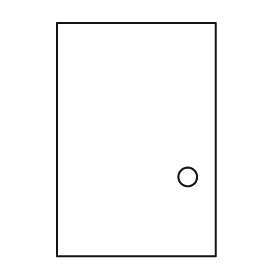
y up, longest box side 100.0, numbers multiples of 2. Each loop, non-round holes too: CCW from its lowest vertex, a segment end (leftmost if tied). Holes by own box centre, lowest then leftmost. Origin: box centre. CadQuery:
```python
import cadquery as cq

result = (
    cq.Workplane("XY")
    .moveTo(-34.0, -50.0)
    .lineTo(34.0, -50.0)
    .lineTo(34.0, 50.0)
    .lineTo(-34.0, 50.0)
    .close()
    .moveTo(22.0, -16.0)
    .circle(4.0)
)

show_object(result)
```